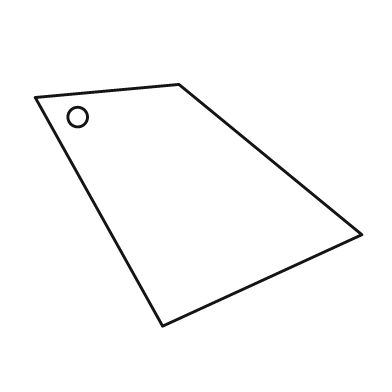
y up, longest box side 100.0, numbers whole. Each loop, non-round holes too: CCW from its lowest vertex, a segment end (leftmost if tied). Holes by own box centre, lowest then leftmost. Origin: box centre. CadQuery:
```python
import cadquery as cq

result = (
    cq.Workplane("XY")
    .moveTo(-11.0, -37.0)
    .lineTo(50.0, -9.0)
    .lineTo(-6.0, 37.0)
    .lineTo(-50.0, 33.0)
    .close()
    .moveTo(-37.0, 27.0)
    .circle(3.0)
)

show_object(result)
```